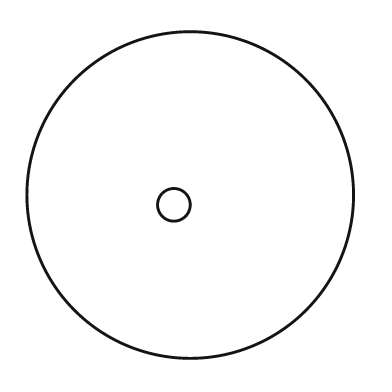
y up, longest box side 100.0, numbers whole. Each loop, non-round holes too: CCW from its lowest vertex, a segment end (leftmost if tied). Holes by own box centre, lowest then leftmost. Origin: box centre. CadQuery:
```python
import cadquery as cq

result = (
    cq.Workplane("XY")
    .moveTo(0.0, 0.0)
    .circle(50.0)
    .moveTo(-5.0, -3.0)
    .circle(5.0)
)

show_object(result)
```